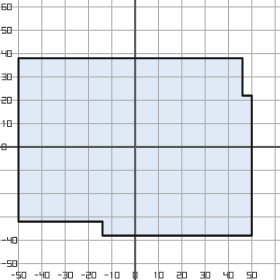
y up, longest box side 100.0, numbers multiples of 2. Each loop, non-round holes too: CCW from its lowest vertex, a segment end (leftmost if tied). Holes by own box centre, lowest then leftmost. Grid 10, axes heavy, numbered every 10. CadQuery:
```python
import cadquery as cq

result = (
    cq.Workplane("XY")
    .moveTo(-14.0, -38.0)
    .lineTo(50.0, -38.0)
    .lineTo(50.0, 22.0)
    .lineTo(46.0, 22.0)
    .lineTo(46.0, 38.0)
    .lineTo(-50.0, 38.0)
    .lineTo(-50.0, -32.0)
    .lineTo(-14.0, -32.0)
    .close()
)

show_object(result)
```